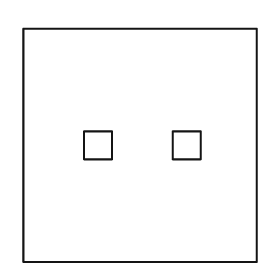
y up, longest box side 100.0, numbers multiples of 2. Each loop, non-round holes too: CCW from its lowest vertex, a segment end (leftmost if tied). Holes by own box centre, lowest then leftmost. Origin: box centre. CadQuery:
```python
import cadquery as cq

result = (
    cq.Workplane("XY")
    .moveTo(-50.0, -50.0)
    .lineTo(50.0, -50.0)
    .lineTo(50.0, 50.0)
    .lineTo(-50.0, 50.0)
    .close()
    .moveTo(-24.0, -6.0)
    .lineTo(-12.0, -6.0)
    .lineTo(-12.0, 6.0)
    .lineTo(-24.0, 6.0)
    .close()
    .moveTo(14.0, -6.0)
    .lineTo(26.0, -6.0)
    .lineTo(26.0, 6.0)
    .lineTo(14.0, 6.0)
    .close()
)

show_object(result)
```